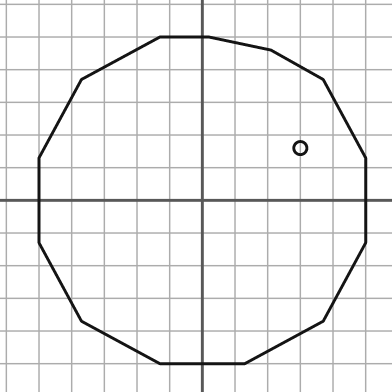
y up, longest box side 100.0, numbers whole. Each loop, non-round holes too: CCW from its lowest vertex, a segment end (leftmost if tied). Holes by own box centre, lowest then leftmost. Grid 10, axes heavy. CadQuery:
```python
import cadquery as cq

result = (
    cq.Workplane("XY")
    .moveTo(-13.0, -50.0)
    .lineTo(13.0, -50.0)
    .lineTo(37.0, -37.0)
    .lineTo(50.0, -13.0)
    .lineTo(50.0, 13.0)
    .lineTo(37.0, 37.0)
    .lineTo(21.0, 46.0)
    .lineTo(2.0, 50.0)
    .lineTo(-13.0, 50.0)
    .lineTo(-37.0, 37.0)
    .lineTo(-50.0, 13.0)
    .lineTo(-50.0, -13.0)
    .lineTo(-37.0, -37.0)
    .close()
    .moveTo(30.0, 16.0)
    .circle(2.0)
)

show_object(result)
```